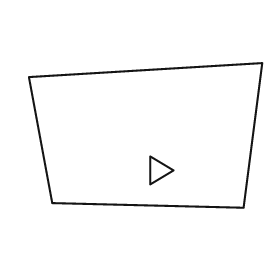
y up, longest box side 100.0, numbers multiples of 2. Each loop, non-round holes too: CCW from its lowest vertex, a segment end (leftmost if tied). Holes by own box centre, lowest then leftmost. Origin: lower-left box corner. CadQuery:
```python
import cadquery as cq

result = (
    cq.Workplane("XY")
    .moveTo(92.0, 0.0)
    .lineTo(100.0, 62.0)
    .lineTo(0.0, 56.0)
    .lineTo(10.0, 2.0)
    .close()
    .moveTo(52.0, 10.0)
    .lineTo(62.0, 16.0)
    .lineTo(52.0, 22.0)
    .close()
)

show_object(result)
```